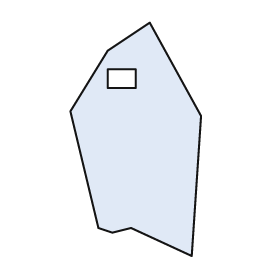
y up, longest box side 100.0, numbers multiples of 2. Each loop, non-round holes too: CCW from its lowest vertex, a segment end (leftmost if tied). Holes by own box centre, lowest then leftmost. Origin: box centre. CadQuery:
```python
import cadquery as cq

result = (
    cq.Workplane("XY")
    .moveTo(24.0, -50.0)
    .lineTo(28.0, 10.0)
    .lineTo(6.0, 50.0)
    .lineTo(-12.0, 38.0)
    .lineTo(-28.0, 12.0)
    .lineTo(-16.0, -38.0)
    .lineTo(-10.0, -40.0)
    .lineTo(-2.0, -38.0)
    .close()
    .moveTo(-12.0, 22.0)
    .lineTo(0.0, 22.0)
    .lineTo(0.0, 30.0)
    .lineTo(-12.0, 30.0)
    .close()
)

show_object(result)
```